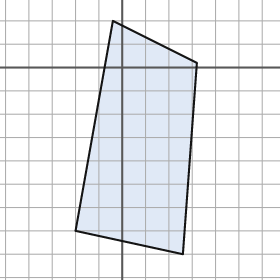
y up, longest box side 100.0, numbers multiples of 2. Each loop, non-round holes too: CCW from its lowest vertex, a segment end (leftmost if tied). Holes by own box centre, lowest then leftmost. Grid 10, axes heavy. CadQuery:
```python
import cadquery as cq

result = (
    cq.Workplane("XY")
    .moveTo(26.0, -80.0)
    .lineTo(32.0, 2.0)
    .lineTo(-4.0, 20.0)
    .lineTo(-20.0, -70.0)
    .close()
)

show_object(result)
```